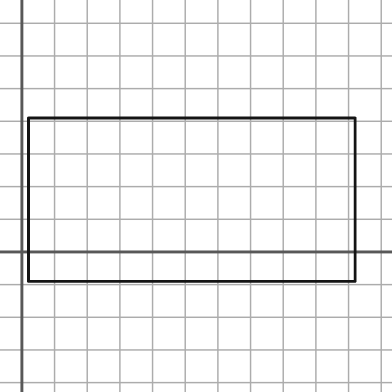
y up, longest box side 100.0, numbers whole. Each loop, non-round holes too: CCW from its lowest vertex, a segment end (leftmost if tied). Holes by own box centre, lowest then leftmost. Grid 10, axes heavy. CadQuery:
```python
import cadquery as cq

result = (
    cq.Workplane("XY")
    .moveTo(2.0, -9.0)
    .lineTo(102.0, -9.0)
    .lineTo(102.0, 41.0)
    .lineTo(2.0, 41.0)
    .close()
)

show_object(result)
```